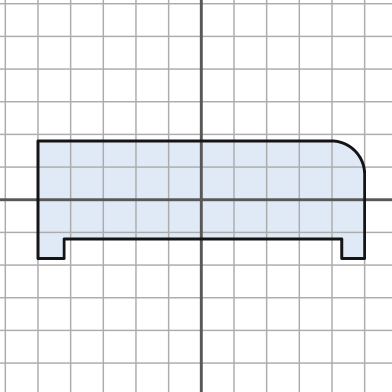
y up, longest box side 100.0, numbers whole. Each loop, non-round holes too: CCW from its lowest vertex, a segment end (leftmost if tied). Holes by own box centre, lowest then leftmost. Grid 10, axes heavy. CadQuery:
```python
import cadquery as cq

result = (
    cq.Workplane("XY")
    .moveTo(-50.0, -18.0)
    .lineTo(-42.0, -18.0)
    .lineTo(-42.0, -12.0)
    .lineTo(43.0, -12.0)
    .lineTo(43.0, -18.0)
    .lineTo(50.0, -18.0)
    .lineTo(50.0, 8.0)
    .threePointArc((47.0, 15.0), (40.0, 18.0))
    .lineTo(-50.0, 18.0)
    .close()
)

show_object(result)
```